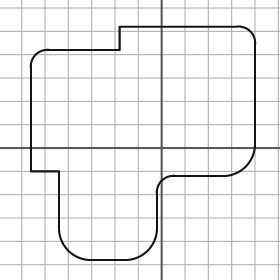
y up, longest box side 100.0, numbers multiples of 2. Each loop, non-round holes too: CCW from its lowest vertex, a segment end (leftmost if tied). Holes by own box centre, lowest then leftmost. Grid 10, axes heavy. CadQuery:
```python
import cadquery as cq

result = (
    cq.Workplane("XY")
    .moveTo(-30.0, -48.0)
    .lineTo(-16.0, -48.0)
    .threePointArc((-6.0, -44.0), (-2.0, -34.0))
    .lineTo(-2.0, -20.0)
    .threePointArc((0.0, -14.0), (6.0, -12.0))
    .lineTo(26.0, -12.0)
    .threePointArc((36.0, -8.0), (40.0, 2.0))
    .lineTo(40.0, 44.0)
    .threePointArc((38.0, 50.0), (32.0, 52.0))
    .lineTo(-18.0, 52.0)
    .lineTo(-18.0, 42.0)
    .lineTo(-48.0, 42.0)
    .threePointArc((-54.0, 40.0), (-56.0, 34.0))
    .lineTo(-56.0, -10.0)
    .lineTo(-44.0, -10.0)
    .lineTo(-44.0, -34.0)
    .threePointArc((-40.0, -44.0), (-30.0, -48.0))
    .close()
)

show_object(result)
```